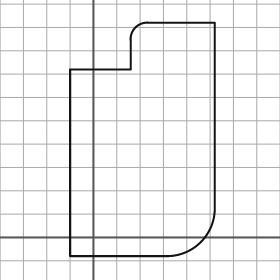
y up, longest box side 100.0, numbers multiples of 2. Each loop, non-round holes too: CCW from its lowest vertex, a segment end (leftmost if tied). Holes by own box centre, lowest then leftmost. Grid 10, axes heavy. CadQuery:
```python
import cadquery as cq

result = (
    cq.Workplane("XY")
    .moveTo(-10.0, -8.0)
    .lineTo(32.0, -8.0)
    .threePointArc((46.0, -2.0), (52.0, 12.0))
    .lineTo(52.0, 92.0)
    .lineTo(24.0, 92.0)
    .threePointArc((18.0, 90.0), (16.0, 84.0))
    .lineTo(16.0, 72.0)
    .lineTo(-10.0, 72.0)
    .close()
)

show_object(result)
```